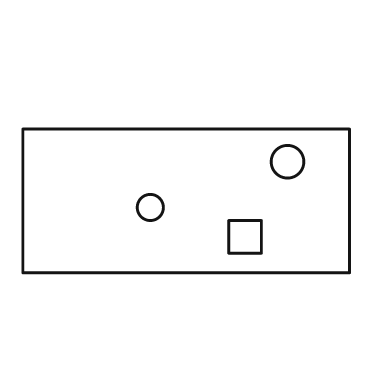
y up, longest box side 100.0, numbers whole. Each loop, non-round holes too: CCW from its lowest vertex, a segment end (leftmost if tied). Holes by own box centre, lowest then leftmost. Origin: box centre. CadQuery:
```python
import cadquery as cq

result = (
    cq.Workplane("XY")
    .moveTo(-50.0, -22.0)
    .lineTo(50.0, -22.0)
    .lineTo(50.0, 22.0)
    .lineTo(-50.0, 22.0)
    .close()
    .moveTo(13.0, -16.0)
    .lineTo(23.0, -16.0)
    .lineTo(23.0, -6.0)
    .lineTo(13.0, -6.0)
    .close()
    .moveTo(-11.0, -2.0)
    .circle(4.0)
    .moveTo(31.0, 12.0)
    .circle(5.0)
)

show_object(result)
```